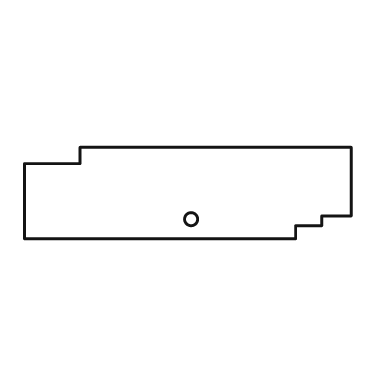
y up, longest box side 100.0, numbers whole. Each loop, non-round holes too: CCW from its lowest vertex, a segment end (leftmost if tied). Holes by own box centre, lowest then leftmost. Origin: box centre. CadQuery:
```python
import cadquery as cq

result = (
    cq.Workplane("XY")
    .moveTo(-50.0, -14.0)
    .lineTo(33.0, -14.0)
    .lineTo(33.0, -10.0)
    .lineTo(41.0, -10.0)
    .lineTo(41.0, -7.0)
    .lineTo(50.0, -7.0)
    .lineTo(50.0, 14.0)
    .lineTo(-33.0, 14.0)
    .lineTo(-33.0, 9.0)
    .lineTo(-50.0, 9.0)
    .close()
    .moveTo(1.0, -8.0)
    .circle(2.0)
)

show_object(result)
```